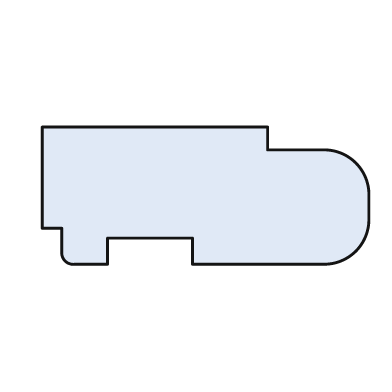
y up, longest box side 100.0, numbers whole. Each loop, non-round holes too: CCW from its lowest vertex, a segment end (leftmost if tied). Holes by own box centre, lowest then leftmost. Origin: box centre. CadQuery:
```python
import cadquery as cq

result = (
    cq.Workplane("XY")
    .moveTo(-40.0, -21.0)
    .lineTo(-30.0, -21.0)
    .lineTo(-30.0, -13.0)
    .lineTo(-4.0, -13.0)
    .lineTo(-4.0, -21.0)
    .lineTo(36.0, -21.0)
    .threePointArc((46.0, -17.0), (50.0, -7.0))
    .lineTo(50.0, 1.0)
    .threePointArc((46.0, 10.0), (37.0, 14.0))
    .lineTo(19.0, 14.0)
    .lineTo(19.0, 21.0)
    .lineTo(-50.0, 21.0)
    .lineTo(-50.0, -10.0)
    .lineTo(-44.0, -10.0)
    .lineTo(-44.0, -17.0)
    .threePointArc((-43.0, -20.0), (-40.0, -21.0))
    .close()
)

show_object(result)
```